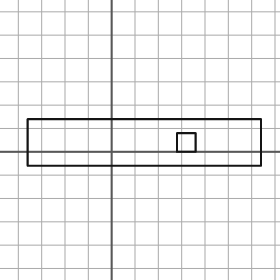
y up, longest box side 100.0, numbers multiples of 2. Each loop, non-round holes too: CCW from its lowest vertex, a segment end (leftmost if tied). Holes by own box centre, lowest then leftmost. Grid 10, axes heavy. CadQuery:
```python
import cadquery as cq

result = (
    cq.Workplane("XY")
    .moveTo(-36.0, -6.0)
    .lineTo(64.0, -6.0)
    .lineTo(64.0, 14.0)
    .lineTo(-36.0, 14.0)
    .close()
    .moveTo(28.0, 0.0)
    .lineTo(36.0, 0.0)
    .lineTo(36.0, 8.0)
    .lineTo(28.0, 8.0)
    .close()
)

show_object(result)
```